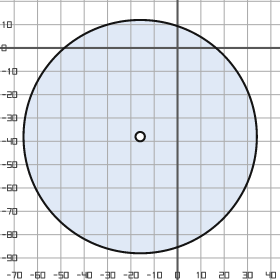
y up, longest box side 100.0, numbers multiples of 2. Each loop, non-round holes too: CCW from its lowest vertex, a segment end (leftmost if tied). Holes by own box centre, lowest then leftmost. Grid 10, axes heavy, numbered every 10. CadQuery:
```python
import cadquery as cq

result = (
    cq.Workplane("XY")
    .moveTo(-16.0, -38.0)
    .circle(50.0)
    .moveTo(-16.0, -38.0)
    .circle(2.0)
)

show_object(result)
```